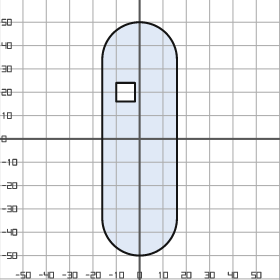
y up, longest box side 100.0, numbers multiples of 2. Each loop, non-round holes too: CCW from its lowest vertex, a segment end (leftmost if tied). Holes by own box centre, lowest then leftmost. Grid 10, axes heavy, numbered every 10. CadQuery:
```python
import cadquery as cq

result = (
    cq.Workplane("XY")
    .moveTo(-16.0, -34.0)
    .threePointArc((0.0, -50.0), (16.0, -34.0))
    .lineTo(16.0, 34.0)
    .threePointArc((0.0, 50.0), (-16.0, 34.0))
    .close()
    .moveTo(-10.0, 16.0)
    .lineTo(-2.0, 16.0)
    .lineTo(-2.0, 24.0)
    .lineTo(-10.0, 24.0)
    .close()
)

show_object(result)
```